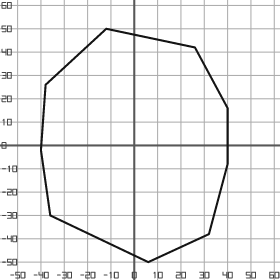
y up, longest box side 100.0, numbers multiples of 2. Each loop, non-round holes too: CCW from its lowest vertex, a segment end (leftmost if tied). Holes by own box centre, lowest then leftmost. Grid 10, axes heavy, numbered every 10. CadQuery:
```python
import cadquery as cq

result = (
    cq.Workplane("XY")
    .moveTo(6.0, -50.0)
    .lineTo(32.0, -38.0)
    .lineTo(40.0, -8.0)
    .lineTo(40.0, 16.0)
    .lineTo(26.0, 42.0)
    .lineTo(-12.0, 50.0)
    .lineTo(-38.0, 26.0)
    .lineTo(-40.0, -2.0)
    .lineTo(-36.0, -30.0)
    .close()
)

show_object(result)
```